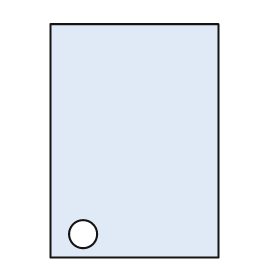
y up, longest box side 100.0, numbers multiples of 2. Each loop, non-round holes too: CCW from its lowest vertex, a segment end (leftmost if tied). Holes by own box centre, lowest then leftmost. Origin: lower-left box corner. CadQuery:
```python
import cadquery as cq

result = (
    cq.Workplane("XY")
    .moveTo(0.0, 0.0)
    .lineTo(72.0, 0.0)
    .lineTo(72.0, 100.0)
    .lineTo(0.0, 100.0)
    .close()
    .moveTo(14.0, 10.0)
    .circle(6.0)
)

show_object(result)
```